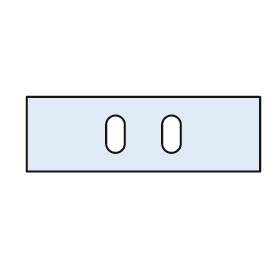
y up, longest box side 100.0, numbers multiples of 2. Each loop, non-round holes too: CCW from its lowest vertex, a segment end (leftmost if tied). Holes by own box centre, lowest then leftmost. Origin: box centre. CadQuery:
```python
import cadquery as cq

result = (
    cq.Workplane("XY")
    .moveTo(-50.0, -16.0)
    .lineTo(50.0, -16.0)
    .lineTo(50.0, 16.0)
    .lineTo(-50.0, 16.0)
    .close()
    .moveTo(-16.0, -4.0)
    .threePointArc((-12.0, -8.0), (-8.0, -4.0))
    .lineTo(-8.0, 4.0)
    .threePointArc((-12.0, 8.0), (-16.0, 4.0))
    .close()
    .moveTo(8.0, -4.0)
    .threePointArc((12.0, -8.0), (16.0, -4.0))
    .lineTo(16.0, 4.0)
    .threePointArc((12.0, 8.0), (8.0, 4.0))
    .close()
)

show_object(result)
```